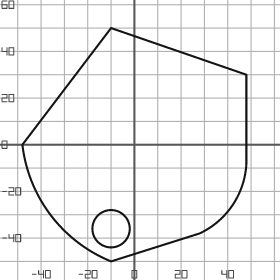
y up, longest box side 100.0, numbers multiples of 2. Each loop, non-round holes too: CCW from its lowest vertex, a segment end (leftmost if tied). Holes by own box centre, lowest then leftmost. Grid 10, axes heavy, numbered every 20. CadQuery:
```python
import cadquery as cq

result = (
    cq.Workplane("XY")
    .moveTo(-10.0, -50.0)
    .lineTo(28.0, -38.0)
    .threePointArc((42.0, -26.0), (48.0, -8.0))
    .lineTo(48.0, 30.0)
    .lineTo(-10.0, 50.0)
    .lineTo(-48.0, 0.0)
    .threePointArc((-36.0, -30.0), (-10.0, -50.0))
    .close()
    .moveTo(-10.0, -36.0)
    .circle(8.0)
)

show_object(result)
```